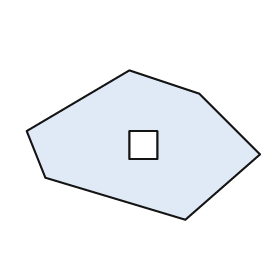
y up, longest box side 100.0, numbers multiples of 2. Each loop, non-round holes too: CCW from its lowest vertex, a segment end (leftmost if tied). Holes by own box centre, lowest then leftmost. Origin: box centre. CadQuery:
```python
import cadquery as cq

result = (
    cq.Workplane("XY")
    .moveTo(18.0, -32.0)
    .lineTo(50.0, -4.0)
    .lineTo(24.0, 22.0)
    .lineTo(-6.0, 32.0)
    .lineTo(-50.0, 6.0)
    .lineTo(-42.0, -14.0)
    .close()
    .moveTo(-6.0, -6.0)
    .lineTo(6.0, -6.0)
    .lineTo(6.0, 6.0)
    .lineTo(-6.0, 6.0)
    .close()
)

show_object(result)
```